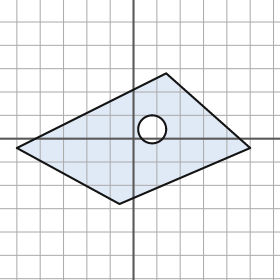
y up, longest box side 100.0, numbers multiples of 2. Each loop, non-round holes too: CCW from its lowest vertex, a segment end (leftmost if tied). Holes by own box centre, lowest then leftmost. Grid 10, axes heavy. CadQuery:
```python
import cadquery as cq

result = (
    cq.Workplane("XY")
    .moveTo(-6.0, -28.0)
    .lineTo(50.0, -4.0)
    .lineTo(14.0, 28.0)
    .lineTo(-50.0, -4.0)
    .close()
    .moveTo(8.0, 4.0)
    .circle(6.0)
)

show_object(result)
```